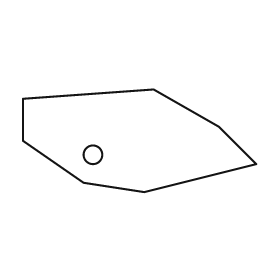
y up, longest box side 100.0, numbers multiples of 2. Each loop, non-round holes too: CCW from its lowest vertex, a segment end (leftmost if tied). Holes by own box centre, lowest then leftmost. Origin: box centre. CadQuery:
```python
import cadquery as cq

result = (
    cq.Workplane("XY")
    .moveTo(2.0, -22.0)
    .lineTo(50.0, -10.0)
    .lineTo(34.0, 6.0)
    .lineTo(6.0, 22.0)
    .lineTo(-50.0, 18.0)
    .lineTo(-50.0, 0.0)
    .lineTo(-24.0, -18.0)
    .close()
    .moveTo(-20.0, -6.0)
    .circle(4.0)
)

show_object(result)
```